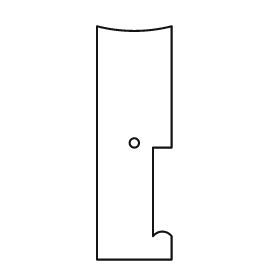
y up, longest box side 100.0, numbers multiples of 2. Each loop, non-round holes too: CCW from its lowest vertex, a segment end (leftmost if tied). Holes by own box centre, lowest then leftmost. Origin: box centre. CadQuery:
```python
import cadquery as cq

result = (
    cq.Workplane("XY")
    .moveTo(-16.0, -50.0)
    .lineTo(16.0, -50.0)
    .lineTo(16.0, -40.0)
    .threePointArc((12.0, -38.0), (8.0, -40.0))
    .lineTo(8.0, -2.0)
    .lineTo(16.0, -2.0)
    .lineTo(16.0, 50.0)
    .threePointArc((0.0, 48.0), (-16.0, 50.0))
    .close()
    .moveTo(0.0, 0.0)
    .circle(2.0)
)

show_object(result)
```